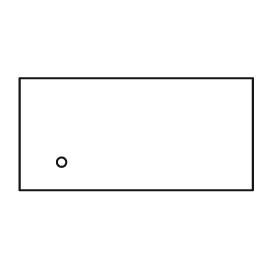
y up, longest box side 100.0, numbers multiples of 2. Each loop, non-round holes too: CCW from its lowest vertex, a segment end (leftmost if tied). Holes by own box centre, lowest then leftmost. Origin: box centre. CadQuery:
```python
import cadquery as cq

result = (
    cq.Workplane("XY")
    .moveTo(-50.0, -24.0)
    .lineTo(50.0, -24.0)
    .lineTo(50.0, 24.0)
    .lineTo(-50.0, 24.0)
    .close()
    .moveTo(-32.0, -12.0)
    .circle(2.0)
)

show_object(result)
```